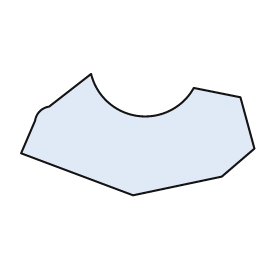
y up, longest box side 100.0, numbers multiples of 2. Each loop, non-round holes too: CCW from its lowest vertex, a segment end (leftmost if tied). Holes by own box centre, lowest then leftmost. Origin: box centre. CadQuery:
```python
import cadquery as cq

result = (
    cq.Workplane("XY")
    .moveTo(-2.0, -26.0)
    .lineTo(36.0, -18.0)
    .lineTo(50.0, -6.0)
    .lineTo(44.0, 16.0)
    .lineTo(24.0, 20.0)
    .threePointArc((0.0, 8.0), (-20.0, 26.0))
    .lineTo(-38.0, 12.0)
    .threePointArc((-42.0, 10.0), (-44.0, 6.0))
    .lineTo(-50.0, -8.0)
    .close()
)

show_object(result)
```